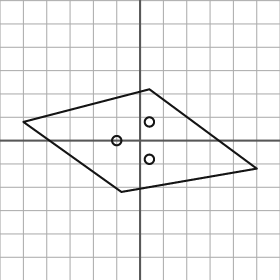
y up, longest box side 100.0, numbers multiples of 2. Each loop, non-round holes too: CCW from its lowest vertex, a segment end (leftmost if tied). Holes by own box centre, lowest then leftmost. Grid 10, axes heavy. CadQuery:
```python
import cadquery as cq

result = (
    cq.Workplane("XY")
    .moveTo(-8.0, -22.0)
    .lineTo(50.0, -12.0)
    .lineTo(4.0, 22.0)
    .lineTo(-50.0, 8.0)
    .close()
    .moveTo(4.0, -8.0)
    .circle(2.0)
    .moveTo(-10.0, 0.0)
    .circle(2.0)
    .moveTo(4.0, 8.0)
    .circle(2.0)
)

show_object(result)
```